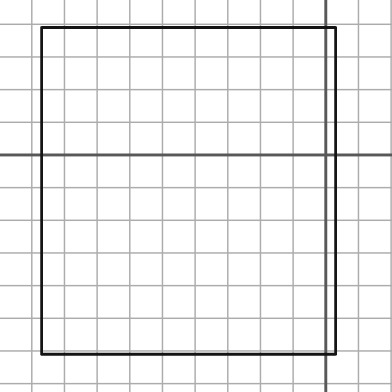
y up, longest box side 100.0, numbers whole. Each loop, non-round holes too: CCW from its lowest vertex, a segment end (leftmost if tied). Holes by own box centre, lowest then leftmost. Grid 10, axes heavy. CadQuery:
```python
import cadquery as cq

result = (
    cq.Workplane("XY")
    .moveTo(-87.0, -61.0)
    .lineTo(3.0, -61.0)
    .lineTo(3.0, 39.0)
    .lineTo(-87.0, 39.0)
    .close()
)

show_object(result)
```